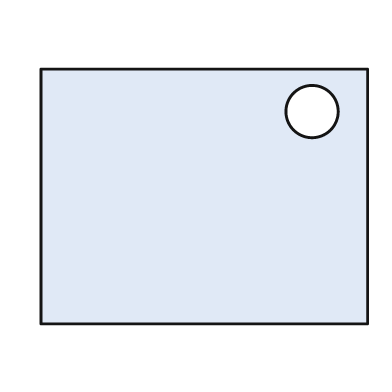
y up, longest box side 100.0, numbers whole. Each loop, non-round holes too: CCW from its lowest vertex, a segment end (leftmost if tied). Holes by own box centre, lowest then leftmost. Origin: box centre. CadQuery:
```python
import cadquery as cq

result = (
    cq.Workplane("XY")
    .moveTo(-50.0, -39.0)
    .lineTo(50.0, -39.0)
    .lineTo(50.0, 39.0)
    .lineTo(-50.0, 39.0)
    .close()
    .moveTo(33.0, 26.0)
    .circle(8.0)
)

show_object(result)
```